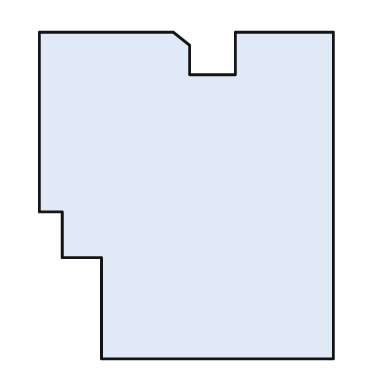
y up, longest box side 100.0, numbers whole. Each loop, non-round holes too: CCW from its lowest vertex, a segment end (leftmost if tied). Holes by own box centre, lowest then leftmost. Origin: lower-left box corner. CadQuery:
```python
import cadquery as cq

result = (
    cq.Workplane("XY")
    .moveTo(19.0, 0.0)
    .lineTo(90.0, 0.0)
    .lineTo(90.0, 100.0)
    .lineTo(60.0, 100.0)
    .lineTo(60.0, 87.0)
    .lineTo(46.0, 87.0)
    .lineTo(46.0, 96.0)
    .lineTo(41.0, 100.0)
    .lineTo(0.0, 100.0)
    .lineTo(0.0, 45.0)
    .lineTo(7.0, 45.0)
    .lineTo(7.0, 31.0)
    .lineTo(19.0, 31.0)
    .close()
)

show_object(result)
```